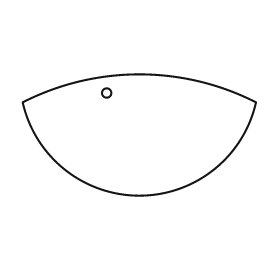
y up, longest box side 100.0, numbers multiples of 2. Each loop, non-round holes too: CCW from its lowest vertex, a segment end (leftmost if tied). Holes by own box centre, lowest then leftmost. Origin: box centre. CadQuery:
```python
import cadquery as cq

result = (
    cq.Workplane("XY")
    .moveTo(-50.0, 14.0)
    .threePointArc((0.0, -26.0), (50.0, 14.0))
    .threePointArc((0.0, 26.0), (-50.0, 14.0))
    .close()
    .moveTo(-14.0, 18.0)
    .circle(2.0)
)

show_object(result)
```